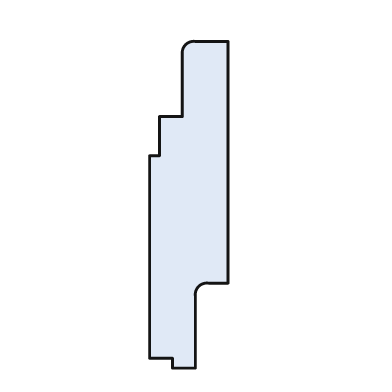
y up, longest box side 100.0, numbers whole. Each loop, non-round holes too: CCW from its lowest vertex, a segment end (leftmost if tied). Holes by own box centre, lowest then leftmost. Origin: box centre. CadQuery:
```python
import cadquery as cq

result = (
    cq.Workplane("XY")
    .moveTo(-5.0, -50.0)
    .lineTo(2.0, -50.0)
    .lineTo(2.0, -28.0)
    .threePointArc((3.0, -25.0), (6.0, -24.0))
    .lineTo(12.0, -24.0)
    .lineTo(12.0, 50.0)
    .lineTo(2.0, 50.0)
    .threePointArc((-1.0, 49.0), (-2.0, 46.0))
    .lineTo(-2.0, 27.0)
    .lineTo(-9.0, 27.0)
    .lineTo(-9.0, 15.0)
    .lineTo(-12.0, 15.0)
    .lineTo(-12.0, -47.0)
    .lineTo(-5.0, -47.0)
    .close()
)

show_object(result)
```